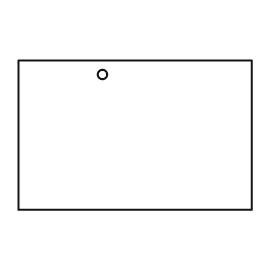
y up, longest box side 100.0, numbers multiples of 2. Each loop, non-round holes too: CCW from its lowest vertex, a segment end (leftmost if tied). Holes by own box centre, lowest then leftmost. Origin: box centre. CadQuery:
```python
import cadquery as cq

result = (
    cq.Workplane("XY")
    .moveTo(-50.0, -32.0)
    .lineTo(50.0, -32.0)
    .lineTo(50.0, 32.0)
    .lineTo(-50.0, 32.0)
    .close()
    .moveTo(-14.0, 26.0)
    .circle(2.0)
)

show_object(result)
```